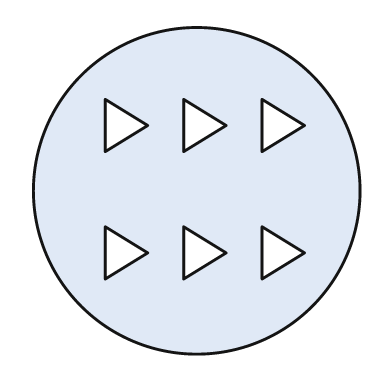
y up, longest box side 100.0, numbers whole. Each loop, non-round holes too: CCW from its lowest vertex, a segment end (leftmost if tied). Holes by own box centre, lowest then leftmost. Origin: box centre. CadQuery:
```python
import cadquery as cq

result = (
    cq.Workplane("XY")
    .moveTo(0.0, 0.0)
    .circle(50.0)
    .moveTo(-28.0, -27.0)
    .lineTo(-15.0, -19.0)
    .lineTo(-28.0, -11.0)
    .close()
    .moveTo(-4.0, -27.0)
    .lineTo(9.0, -19.0)
    .lineTo(-4.0, -11.0)
    .close()
    .moveTo(20.0, -27.0)
    .lineTo(33.0, -19.0)
    .lineTo(20.0, -11.0)
    .close()
    .moveTo(-28.0, 12.0)
    .lineTo(-15.0, 20.0)
    .lineTo(-28.0, 28.0)
    .close()
    .moveTo(-4.0, 12.0)
    .lineTo(9.0, 20.0)
    .lineTo(-4.0, 28.0)
    .close()
    .moveTo(20.0, 12.0)
    .lineTo(33.0, 20.0)
    .lineTo(20.0, 28.0)
    .close()
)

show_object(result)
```